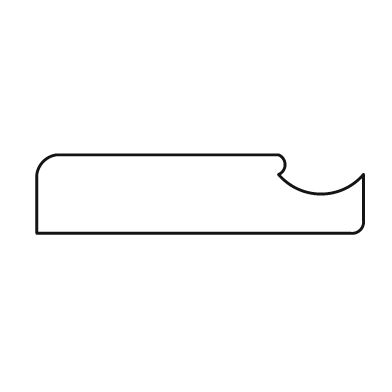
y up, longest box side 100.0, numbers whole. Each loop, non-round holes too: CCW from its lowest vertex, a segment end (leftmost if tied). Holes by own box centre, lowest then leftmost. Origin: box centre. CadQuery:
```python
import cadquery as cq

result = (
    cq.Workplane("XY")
    .moveTo(-50.0, -12.0)
    .lineTo(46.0, -12.0)
    .threePointArc((49.0, -11.0), (50.0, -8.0))
    .lineTo(50.0, 6.0)
    .threePointArc((37.0, 0.0), (24.0, 6.0))
    .threePointArc((26.0, 9.0), (24.0, 12.0))
    .lineTo(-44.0, 12.0)
    .threePointArc((-48.0, 10.0), (-50.0, 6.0))
    .close()
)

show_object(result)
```